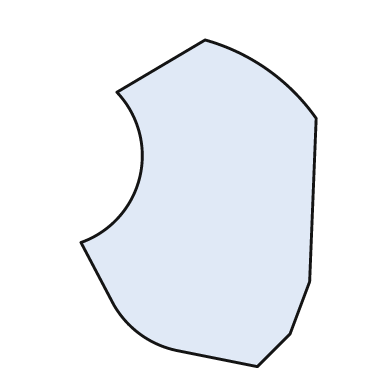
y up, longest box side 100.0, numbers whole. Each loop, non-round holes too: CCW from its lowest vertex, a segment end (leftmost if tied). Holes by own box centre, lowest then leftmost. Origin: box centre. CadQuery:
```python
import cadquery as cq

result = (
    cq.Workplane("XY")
    .moveTo(18.0, -50.0)
    .lineTo(28.0, -40.0)
    .lineTo(34.0, -24.0)
    .lineTo(36.0, 26.0)
    .threePointArc((21.0, 41.0), (2.0, 50.0))
    .lineTo(-25.0, 34.0)
    .threePointArc((-18.0, 8.0), (-36.0, -12.0))
    .lineTo(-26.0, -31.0)
    .threePointArc((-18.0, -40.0), (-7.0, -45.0))
    .close()
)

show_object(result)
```